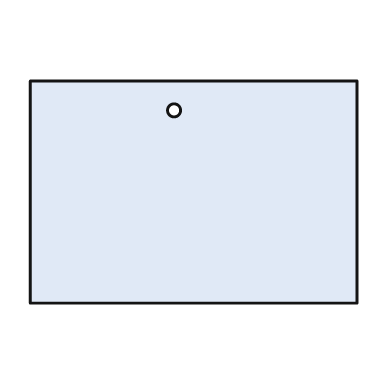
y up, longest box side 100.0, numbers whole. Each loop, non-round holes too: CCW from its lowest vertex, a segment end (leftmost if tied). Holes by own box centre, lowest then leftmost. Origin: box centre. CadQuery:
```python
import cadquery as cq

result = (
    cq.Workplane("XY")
    .moveTo(-50.0, -34.0)
    .lineTo(50.0, -34.0)
    .lineTo(50.0, 34.0)
    .lineTo(-50.0, 34.0)
    .close()
    .moveTo(-6.0, 25.0)
    .circle(2.0)
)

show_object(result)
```